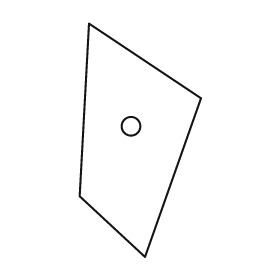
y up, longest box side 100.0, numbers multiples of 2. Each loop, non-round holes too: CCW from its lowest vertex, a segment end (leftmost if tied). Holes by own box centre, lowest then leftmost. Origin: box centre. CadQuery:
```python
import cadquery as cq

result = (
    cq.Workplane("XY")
    .moveTo(2.0, -50.0)
    .lineTo(26.0, 18.0)
    .lineTo(-22.0, 50.0)
    .lineTo(-26.0, -24.0)
    .close()
    .moveTo(-4.0, 6.0)
    .circle(4.0)
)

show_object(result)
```